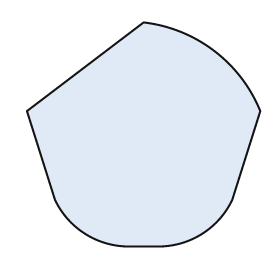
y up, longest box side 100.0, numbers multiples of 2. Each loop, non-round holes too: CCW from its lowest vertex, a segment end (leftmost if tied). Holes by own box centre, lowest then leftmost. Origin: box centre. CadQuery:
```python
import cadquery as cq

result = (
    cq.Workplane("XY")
    .moveTo(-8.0, -48.0)
    .lineTo(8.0, -48.0)
    .threePointArc((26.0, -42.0), (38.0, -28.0))
    .lineTo(50.0, 10.0)
    .threePointArc((30.0, 36.0), (0.0, 48.0))
    .lineTo(-50.0, 10.0)
    .lineTo(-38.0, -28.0)
    .threePointArc((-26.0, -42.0), (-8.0, -48.0))
    .close()
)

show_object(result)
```